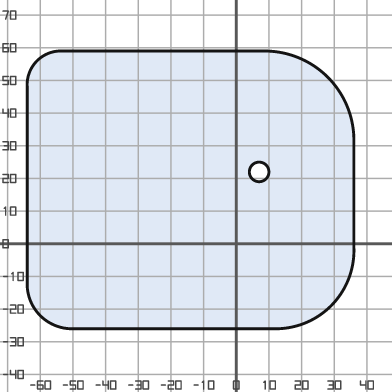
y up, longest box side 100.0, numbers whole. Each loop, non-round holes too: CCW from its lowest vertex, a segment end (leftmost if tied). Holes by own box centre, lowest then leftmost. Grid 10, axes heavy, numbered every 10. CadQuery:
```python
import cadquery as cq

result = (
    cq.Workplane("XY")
    .moveTo(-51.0, -26.0)
    .lineTo(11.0, -26.0)
    .threePointArc((29.0, -19.0), (36.0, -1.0))
    .lineTo(36.0, 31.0)
    .threePointArc((28.0, 51.0), (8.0, 59.0))
    .lineTo(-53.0, 59.0)
    .threePointArc((-61.0, 56.0), (-64.0, 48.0))
    .lineTo(-64.0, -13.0)
    .threePointArc((-60.0, -22.0), (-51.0, -26.0))
    .close()
    .moveTo(7.0, 22.0)
    .circle(3.0)
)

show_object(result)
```